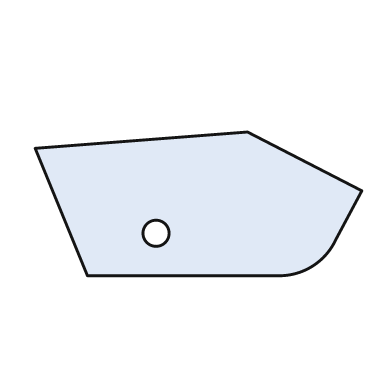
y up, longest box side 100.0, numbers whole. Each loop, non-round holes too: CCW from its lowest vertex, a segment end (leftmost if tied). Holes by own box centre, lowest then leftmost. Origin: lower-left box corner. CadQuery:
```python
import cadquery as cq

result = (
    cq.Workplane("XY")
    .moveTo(16.0, 0.0)
    .lineTo(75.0, 0.0)
    .threePointArc((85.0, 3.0), (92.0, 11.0))
    .lineTo(100.0, 26.0)
    .lineTo(65.0, 44.0)
    .lineTo(0.0, 39.0)
    .close()
    .moveTo(37.0, 13.0)
    .circle(4.0)
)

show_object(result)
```